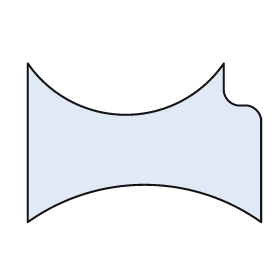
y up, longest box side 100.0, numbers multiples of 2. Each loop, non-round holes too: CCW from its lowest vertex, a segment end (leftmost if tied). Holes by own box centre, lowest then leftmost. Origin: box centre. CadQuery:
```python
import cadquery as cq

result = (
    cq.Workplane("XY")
    .moveTo(-50.0, -34.0)
    .threePointArc((0.0, -18.0), (50.0, -34.0))
    .lineTo(50.0, 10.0)
    .threePointArc((48.0, 14.0), (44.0, 16.0))
    .lineTo(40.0, 16.0)
    .threePointArc((36.0, 18.0), (34.0, 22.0))
    .lineTo(34.0, 34.0)
    .threePointArc((-8.0, 12.0), (-50.0, 34.0))
    .close()
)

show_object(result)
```